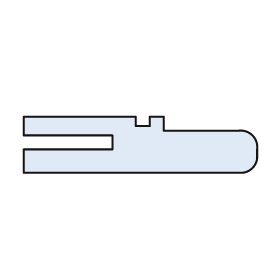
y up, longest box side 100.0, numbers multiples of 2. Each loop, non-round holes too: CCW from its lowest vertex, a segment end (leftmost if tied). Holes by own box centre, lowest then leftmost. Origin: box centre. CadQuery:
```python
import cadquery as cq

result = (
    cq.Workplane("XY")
    .moveTo(-50.0, -12.0)
    .lineTo(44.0, -12.0)
    .threePointArc((48.0, -10.0), (50.0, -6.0))
    .lineTo(50.0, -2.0)
    .threePointArc((48.0, 4.0), (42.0, 6.0))
    .lineTo(10.0, 6.0)
    .lineTo(10.0, 12.0)
    .lineTo(4.0, 12.0)
    .lineTo(4.0, 8.0)
    .lineTo(-2.0, 8.0)
    .lineTo(-2.0, 12.0)
    .lineTo(-50.0, 12.0)
    .lineTo(-50.0, 4.0)
    .lineTo(-12.0, 4.0)
    .lineTo(-12.0, -2.0)
    .lineTo(-50.0, -2.0)
    .close()
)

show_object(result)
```